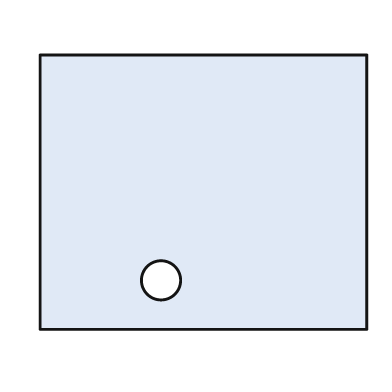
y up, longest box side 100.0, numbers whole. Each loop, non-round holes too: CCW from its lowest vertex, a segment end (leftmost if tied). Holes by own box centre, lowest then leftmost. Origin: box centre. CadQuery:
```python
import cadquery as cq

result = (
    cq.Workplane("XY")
    .moveTo(-50.0, -42.0)
    .lineTo(50.0, -42.0)
    .lineTo(50.0, 42.0)
    .lineTo(-50.0, 42.0)
    .close()
    .moveTo(-13.0, -27.0)
    .circle(6.0)
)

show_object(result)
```